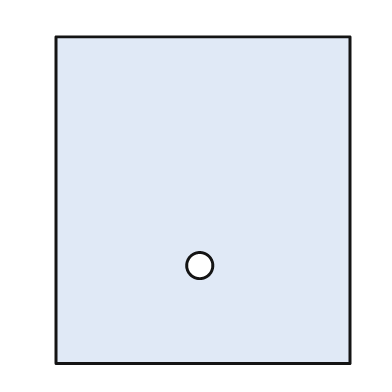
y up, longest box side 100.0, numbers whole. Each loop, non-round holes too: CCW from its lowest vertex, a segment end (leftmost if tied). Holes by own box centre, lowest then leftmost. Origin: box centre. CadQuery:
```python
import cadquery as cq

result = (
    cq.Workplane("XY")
    .moveTo(-45.0, -50.0)
    .lineTo(45.0, -50.0)
    .lineTo(45.0, 50.0)
    .lineTo(-45.0, 50.0)
    .close()
    .moveTo(-1.0, -20.0)
    .circle(4.0)
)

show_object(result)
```